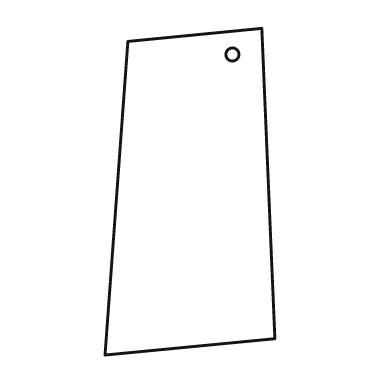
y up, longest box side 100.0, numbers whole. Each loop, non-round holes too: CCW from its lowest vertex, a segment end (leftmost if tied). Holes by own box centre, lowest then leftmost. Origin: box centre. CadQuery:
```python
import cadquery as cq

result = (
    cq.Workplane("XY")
    .moveTo(-26.0, -50.0)
    .lineTo(26.0, -45.0)
    .lineTo(22.0, 50.0)
    .lineTo(-19.0, 46.0)
    .close()
    .moveTo(13.0, 42.0)
    .circle(2.0)
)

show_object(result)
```